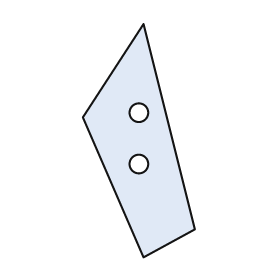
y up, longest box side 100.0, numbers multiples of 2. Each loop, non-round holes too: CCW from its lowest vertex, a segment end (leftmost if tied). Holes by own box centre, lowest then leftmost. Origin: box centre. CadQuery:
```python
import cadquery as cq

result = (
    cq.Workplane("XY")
    .moveTo(2.0, -50.0)
    .lineTo(24.0, -38.0)
    .lineTo(2.0, 50.0)
    .lineTo(-24.0, 10.0)
    .close()
    .moveTo(0.0, -10.0)
    .circle(4.0)
    .moveTo(0.0, 12.0)
    .circle(4.0)
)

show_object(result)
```